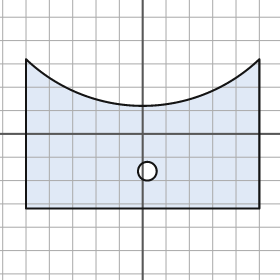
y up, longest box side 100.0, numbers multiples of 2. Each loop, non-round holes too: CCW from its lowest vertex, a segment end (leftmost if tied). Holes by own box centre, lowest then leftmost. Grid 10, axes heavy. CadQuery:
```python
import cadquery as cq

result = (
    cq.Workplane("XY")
    .moveTo(-50.0, -32.0)
    .lineTo(50.0, -32.0)
    .lineTo(50.0, 32.0)
    .threePointArc((0.0, 12.0), (-50.0, 32.0))
    .close()
    .moveTo(2.0, -16.0)
    .circle(4.0)
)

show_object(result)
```